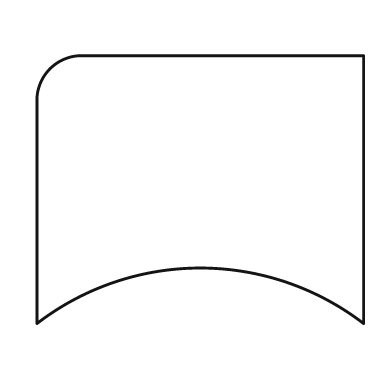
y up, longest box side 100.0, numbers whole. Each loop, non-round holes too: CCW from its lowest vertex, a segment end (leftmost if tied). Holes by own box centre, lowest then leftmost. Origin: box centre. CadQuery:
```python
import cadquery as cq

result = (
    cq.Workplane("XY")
    .moveTo(-50.0, -41.0)
    .threePointArc((0.0, -24.0), (50.0, -41.0))
    .lineTo(50.0, 41.0)
    .lineTo(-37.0, 41.0)
    .threePointArc((-46.0, 37.0), (-50.0, 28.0))
    .close()
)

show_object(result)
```